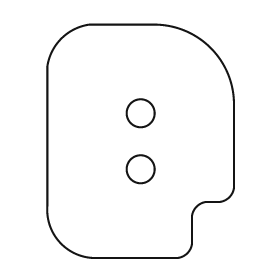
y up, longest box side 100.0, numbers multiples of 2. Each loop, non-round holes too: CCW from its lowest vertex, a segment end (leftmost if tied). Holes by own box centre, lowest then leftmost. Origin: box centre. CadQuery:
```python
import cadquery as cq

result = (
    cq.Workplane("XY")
    .moveTo(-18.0, -50.0)
    .lineTo(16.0, -50.0)
    .threePointArc((20.0, -48.0), (22.0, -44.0))
    .lineTo(22.0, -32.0)
    .threePointArc((24.0, -28.0), (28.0, -26.0))
    .lineTo(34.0, -26.0)
    .threePointArc((38.0, -24.0), (40.0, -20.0))
    .lineTo(40.0, 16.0)
    .threePointArc((30.0, 40.0), (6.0, 50.0))
    .lineTo(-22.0, 50.0)
    .threePointArc((-34.0, 44.0), (-40.0, 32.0))
    .lineTo(-40.0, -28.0)
    .threePointArc((-34.0, -44.0), (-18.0, -50.0))
    .close()
    .moveTo(0.0, -12.0)
    .circle(6.0)
    .moveTo(0.0, 12.0)
    .circle(6.0)
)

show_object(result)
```